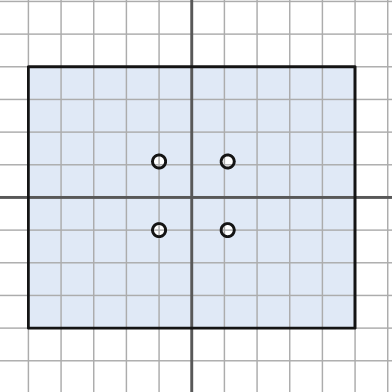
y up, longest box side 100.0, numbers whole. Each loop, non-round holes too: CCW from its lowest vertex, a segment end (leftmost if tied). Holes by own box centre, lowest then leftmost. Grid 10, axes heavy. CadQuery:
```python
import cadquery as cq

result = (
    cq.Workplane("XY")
    .moveTo(-50.0, -40.0)
    .lineTo(50.0, -40.0)
    .lineTo(50.0, 40.0)
    .lineTo(-50.0, 40.0)
    .close()
    .moveTo(-10.0, -10.0)
    .circle(2.0)
    .moveTo(11.0, -10.0)
    .circle(2.0)
    .moveTo(-10.0, 11.0)
    .circle(2.0)
    .moveTo(11.0, 11.0)
    .circle(2.0)
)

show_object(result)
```